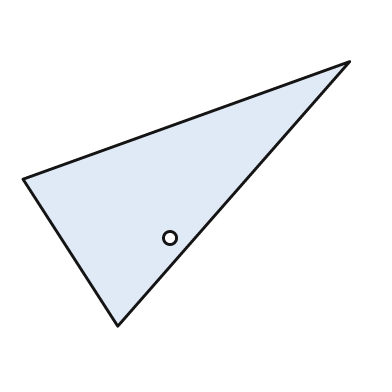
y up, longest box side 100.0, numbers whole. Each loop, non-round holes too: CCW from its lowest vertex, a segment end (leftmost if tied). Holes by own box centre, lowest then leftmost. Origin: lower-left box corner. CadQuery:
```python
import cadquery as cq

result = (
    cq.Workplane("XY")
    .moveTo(29.0, 0.0)
    .lineTo(100.0, 81.0)
    .lineTo(0.0, 45.0)
    .close()
    .moveTo(45.0, 27.0)
    .circle(2.0)
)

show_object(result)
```